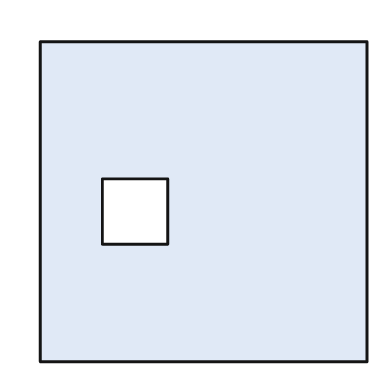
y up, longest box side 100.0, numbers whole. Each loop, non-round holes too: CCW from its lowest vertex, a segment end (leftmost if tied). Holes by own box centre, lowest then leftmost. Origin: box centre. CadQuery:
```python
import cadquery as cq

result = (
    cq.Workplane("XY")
    .moveTo(-50.0, -49.0)
    .lineTo(50.0, -49.0)
    .lineTo(50.0, 49.0)
    .lineTo(-50.0, 49.0)
    .close()
    .moveTo(-31.0, -13.0)
    .lineTo(-11.0, -13.0)
    .lineTo(-11.0, 7.0)
    .lineTo(-31.0, 7.0)
    .close()
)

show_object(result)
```